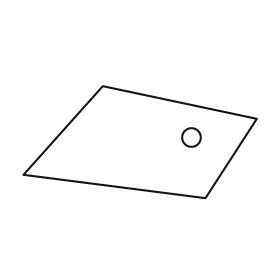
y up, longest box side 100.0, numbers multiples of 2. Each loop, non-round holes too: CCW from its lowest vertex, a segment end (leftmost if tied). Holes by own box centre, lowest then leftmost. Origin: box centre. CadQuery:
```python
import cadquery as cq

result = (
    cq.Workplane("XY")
    .moveTo(28.0, -24.0)
    .lineTo(50.0, 10.0)
    .lineTo(-16.0, 24.0)
    .lineTo(-50.0, -14.0)
    .close()
    .moveTo(22.0, 2.0)
    .circle(4.0)
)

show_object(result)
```